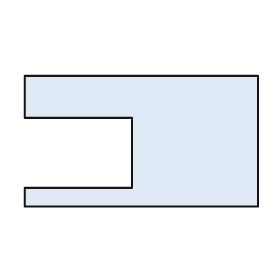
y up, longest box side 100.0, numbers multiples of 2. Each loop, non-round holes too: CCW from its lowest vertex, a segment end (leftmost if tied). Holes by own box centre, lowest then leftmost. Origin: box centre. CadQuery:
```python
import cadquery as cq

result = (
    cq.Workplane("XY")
    .moveTo(-50.0, -28.0)
    .lineTo(50.0, -28.0)
    .lineTo(50.0, 28.0)
    .lineTo(-50.0, 28.0)
    .lineTo(-50.0, 10.0)
    .lineTo(-4.0, 10.0)
    .lineTo(-4.0, -20.0)
    .lineTo(-50.0, -20.0)
    .close()
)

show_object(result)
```